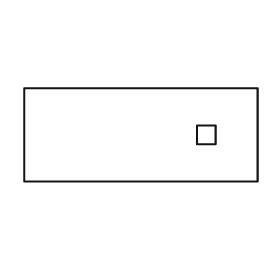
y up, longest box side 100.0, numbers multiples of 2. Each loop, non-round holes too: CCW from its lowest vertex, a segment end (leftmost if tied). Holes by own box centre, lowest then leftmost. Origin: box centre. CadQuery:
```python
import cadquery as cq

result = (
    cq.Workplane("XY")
    .moveTo(-50.0, -20.0)
    .lineTo(50.0, -20.0)
    .lineTo(50.0, 20.0)
    .lineTo(-50.0, 20.0)
    .close()
    .moveTo(24.0, -4.0)
    .lineTo(32.0, -4.0)
    .lineTo(32.0, 4.0)
    .lineTo(24.0, 4.0)
    .close()
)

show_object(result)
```